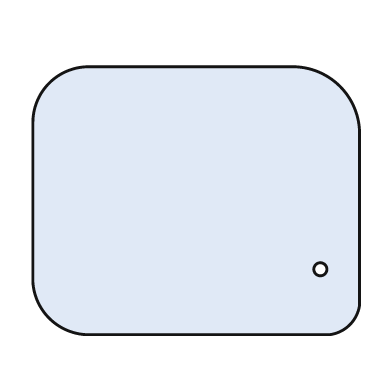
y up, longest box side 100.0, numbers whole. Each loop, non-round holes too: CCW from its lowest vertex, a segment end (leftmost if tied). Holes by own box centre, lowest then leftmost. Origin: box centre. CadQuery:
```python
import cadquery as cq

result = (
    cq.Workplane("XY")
    .moveTo(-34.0, -41.0)
    .lineTo(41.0, -41.0)
    .threePointArc((47.0, -38.0), (50.0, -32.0))
    .lineTo(50.0, 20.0)
    .threePointArc((44.0, 35.0), (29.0, 41.0))
    .lineTo(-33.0, 41.0)
    .threePointArc((-45.0, 36.0), (-50.0, 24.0))
    .lineTo(-50.0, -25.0)
    .threePointArc((-45.0, -36.0), (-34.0, -41.0))
    .close()
    .moveTo(38.0, -21.0)
    .circle(2.0)
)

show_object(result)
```